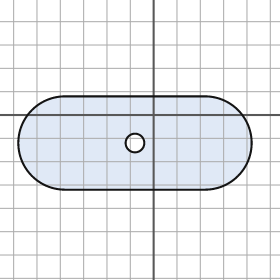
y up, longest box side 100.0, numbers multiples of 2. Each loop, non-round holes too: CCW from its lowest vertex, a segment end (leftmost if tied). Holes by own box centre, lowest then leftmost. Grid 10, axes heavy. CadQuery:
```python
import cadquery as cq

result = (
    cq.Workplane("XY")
    .moveTo(-38.0, -32.0)
    .lineTo(22.0, -32.0)
    .threePointArc((42.0, -12.0), (22.0, 8.0))
    .lineTo(-38.0, 8.0)
    .threePointArc((-58.0, -12.0), (-38.0, -32.0))
    .close()
    .moveTo(-8.0, -12.0)
    .circle(4.0)
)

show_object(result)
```